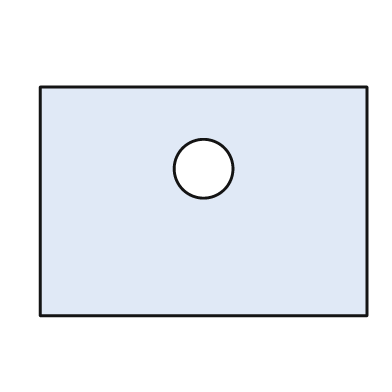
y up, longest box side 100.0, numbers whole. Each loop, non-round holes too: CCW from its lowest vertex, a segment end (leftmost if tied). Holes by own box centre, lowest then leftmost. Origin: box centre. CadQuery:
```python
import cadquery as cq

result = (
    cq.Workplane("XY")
    .moveTo(-50.0, -35.0)
    .lineTo(50.0, -35.0)
    .lineTo(50.0, 35.0)
    .lineTo(-50.0, 35.0)
    .close()
    .moveTo(0.0, 10.0)
    .circle(9.0)
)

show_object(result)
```